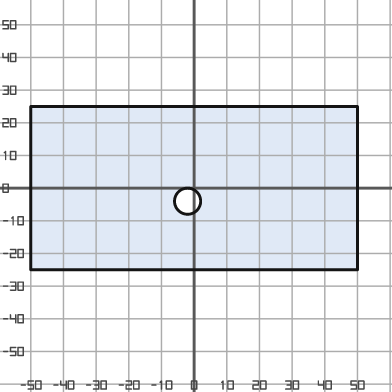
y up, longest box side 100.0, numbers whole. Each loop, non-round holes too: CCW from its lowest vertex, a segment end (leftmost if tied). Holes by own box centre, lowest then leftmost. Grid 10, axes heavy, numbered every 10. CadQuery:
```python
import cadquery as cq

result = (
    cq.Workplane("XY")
    .moveTo(-50.0, -25.0)
    .lineTo(50.0, -25.0)
    .lineTo(50.0, 25.0)
    .lineTo(-50.0, 25.0)
    .close()
    .moveTo(-2.0, -4.0)
    .circle(4.0)
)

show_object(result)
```